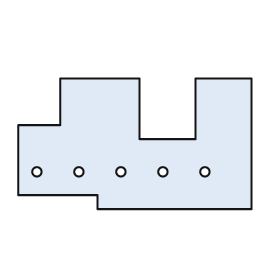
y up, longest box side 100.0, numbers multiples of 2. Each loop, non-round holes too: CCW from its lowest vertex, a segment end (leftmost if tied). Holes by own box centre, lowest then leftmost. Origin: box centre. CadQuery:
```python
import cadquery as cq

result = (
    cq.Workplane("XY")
    .moveTo(-16.0, -28.0)
    .lineTo(50.0, -28.0)
    .lineTo(50.0, 28.0)
    .lineTo(26.0, 28.0)
    .lineTo(26.0, 2.0)
    .lineTo(2.0, 2.0)
    .lineTo(2.0, 28.0)
    .lineTo(-32.0, 28.0)
    .lineTo(-32.0, 8.0)
    .lineTo(-50.0, 8.0)
    .lineTo(-50.0, -22.0)
    .lineTo(-16.0, -22.0)
    .close()
    .moveTo(-42.0, -12.0)
    .circle(2.0)
    .moveTo(-24.0, -12.0)
    .circle(2.0)
    .moveTo(-6.0, -12.0)
    .circle(2.0)
    .moveTo(12.0, -12.0)
    .circle(2.0)
    .moveTo(30.0, -12.0)
    .circle(2.0)
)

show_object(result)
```